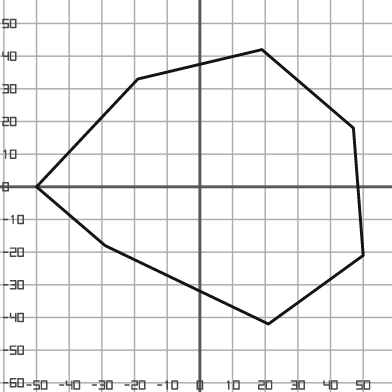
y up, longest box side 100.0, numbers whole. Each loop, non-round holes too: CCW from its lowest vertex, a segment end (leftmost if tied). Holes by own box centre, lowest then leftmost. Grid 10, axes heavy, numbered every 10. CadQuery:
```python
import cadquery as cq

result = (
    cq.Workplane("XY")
    .moveTo(21.0, -42.0)
    .lineTo(50.0, -21.0)
    .lineTo(47.0, 18.0)
    .lineTo(19.0, 42.0)
    .lineTo(-19.0, 33.0)
    .lineTo(-50.0, 0.0)
    .lineTo(-29.0, -18.0)
    .close()
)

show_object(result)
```